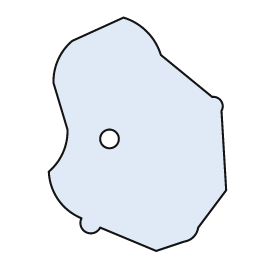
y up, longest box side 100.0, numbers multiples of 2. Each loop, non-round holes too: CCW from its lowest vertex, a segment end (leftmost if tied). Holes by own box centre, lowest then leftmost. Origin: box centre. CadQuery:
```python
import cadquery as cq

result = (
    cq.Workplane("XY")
    .moveTo(8.0, -50.0)
    .lineTo(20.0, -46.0)
    .threePointArc((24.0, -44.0), (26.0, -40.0))
    .lineTo(38.0, -24.0)
    .lineTo(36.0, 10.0)
    .threePointArc((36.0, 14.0), (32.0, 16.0))
    .lineTo(10.0, 34.0)
    .threePointArc((4.0, 44.0), (-6.0, 50.0))
    .lineTo(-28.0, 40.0)
    .threePointArc((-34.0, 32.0), (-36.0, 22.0))
    .lineTo(-30.0, 2.0)
    .threePointArc((-32.0, -8.0), (-38.0, -16.0))
    .threePointArc((-34.0, -28.0), (-24.0, -36.0))
    .threePointArc((-22.0, -42.0), (-16.0, -40.0))
    .close()
    .moveTo(-12.0, -2.0)
    .circle(4.0)
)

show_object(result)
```